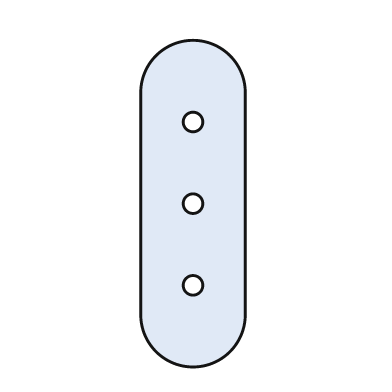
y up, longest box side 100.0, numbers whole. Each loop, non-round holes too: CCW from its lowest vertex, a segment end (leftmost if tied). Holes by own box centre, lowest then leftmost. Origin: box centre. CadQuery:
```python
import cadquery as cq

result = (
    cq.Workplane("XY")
    .moveTo(-16.0, -34.0)
    .threePointArc((0.0, -50.0), (16.0, -34.0))
    .lineTo(16.0, 34.0)
    .threePointArc((0.0, 50.0), (-16.0, 34.0))
    .close()
    .moveTo(0.0, -25.0)
    .circle(3.0)
    .moveTo(0.0, 0.0)
    .circle(3.0)
    .moveTo(0.0, 25.0)
    .circle(3.0)
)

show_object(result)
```